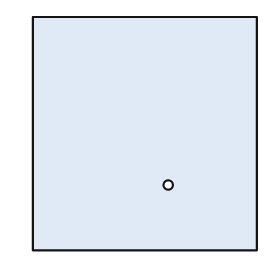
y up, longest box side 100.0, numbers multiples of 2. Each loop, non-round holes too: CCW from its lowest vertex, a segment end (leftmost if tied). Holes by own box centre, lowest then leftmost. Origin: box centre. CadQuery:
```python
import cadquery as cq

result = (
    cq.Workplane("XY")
    .moveTo(-48.0, -50.0)
    .lineTo(48.0, -50.0)
    .lineTo(48.0, 50.0)
    .lineTo(-48.0, 50.0)
    .close()
    .moveTo(10.0, -22.0)
    .circle(2.0)
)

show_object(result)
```